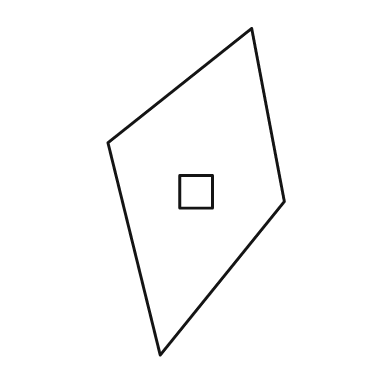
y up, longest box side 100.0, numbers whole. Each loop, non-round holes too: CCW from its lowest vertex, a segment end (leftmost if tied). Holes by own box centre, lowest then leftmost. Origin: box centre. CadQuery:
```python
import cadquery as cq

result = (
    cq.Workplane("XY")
    .moveTo(-11.0, -50.0)
    .lineTo(27.0, -3.0)
    .lineTo(17.0, 50.0)
    .lineTo(-27.0, 15.0)
    .close()
    .moveTo(-5.0, -5.0)
    .lineTo(5.0, -5.0)
    .lineTo(5.0, 5.0)
    .lineTo(-5.0, 5.0)
    .close()
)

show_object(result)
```